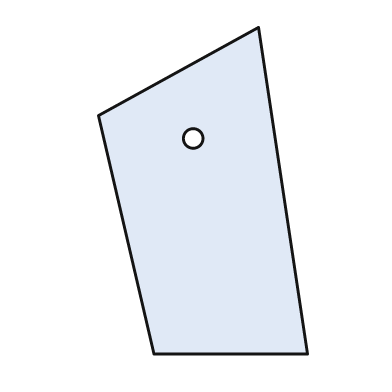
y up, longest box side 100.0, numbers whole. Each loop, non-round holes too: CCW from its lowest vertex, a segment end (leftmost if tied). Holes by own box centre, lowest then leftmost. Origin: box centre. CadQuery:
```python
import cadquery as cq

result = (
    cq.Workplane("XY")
    .moveTo(-15.0, -50.0)
    .lineTo(32.0, -50.0)
    .lineTo(17.0, 50.0)
    .lineTo(-32.0, 23.0)
    .close()
    .moveTo(-3.0, 16.0)
    .circle(3.0)
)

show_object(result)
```